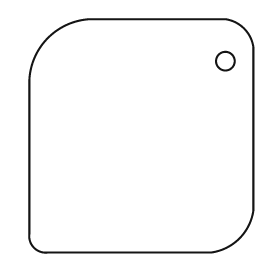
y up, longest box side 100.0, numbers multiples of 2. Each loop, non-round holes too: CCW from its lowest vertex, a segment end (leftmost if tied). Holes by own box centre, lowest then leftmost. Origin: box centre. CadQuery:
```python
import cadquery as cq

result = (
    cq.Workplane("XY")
    .moveTo(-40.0, -50.0)
    .lineTo(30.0, -50.0)
    .threePointArc((42.0, -44.0), (48.0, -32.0))
    .lineTo(48.0, 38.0)
    .threePointArc((44.0, 46.0), (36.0, 50.0))
    .lineTo(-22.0, 50.0)
    .threePointArc((-40.0, 42.0), (-48.0, 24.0))
    .lineTo(-48.0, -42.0)
    .threePointArc((-46.0, -48.0), (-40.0, -50.0))
    .close()
    .moveTo(36.0, 32.0)
    .circle(4.0)
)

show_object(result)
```